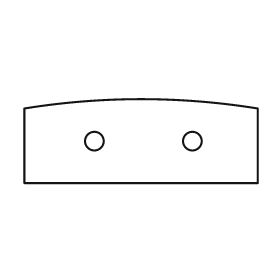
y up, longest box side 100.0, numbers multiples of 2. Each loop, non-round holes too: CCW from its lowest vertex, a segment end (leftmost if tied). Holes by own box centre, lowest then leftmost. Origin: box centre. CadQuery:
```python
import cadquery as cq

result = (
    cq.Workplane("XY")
    .moveTo(-50.0, -18.0)
    .lineTo(50.0, -18.0)
    .lineTo(50.0, 14.0)
    .threePointArc((0.0, 18.0), (-50.0, 14.0))
    .close()
    .moveTo(-20.0, 0.0)
    .circle(4.0)
    .moveTo(22.0, 0.0)
    .circle(4.0)
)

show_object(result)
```